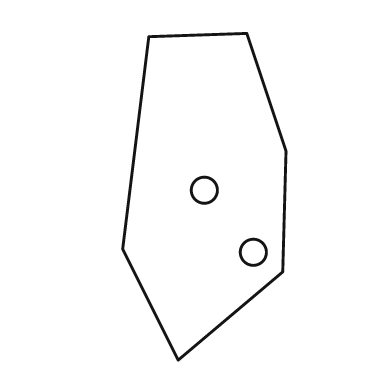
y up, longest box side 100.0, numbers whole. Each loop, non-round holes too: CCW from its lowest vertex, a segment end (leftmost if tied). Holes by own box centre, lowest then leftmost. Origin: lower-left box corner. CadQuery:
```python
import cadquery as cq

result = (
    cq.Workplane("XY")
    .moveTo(17.0, 0.0)
    .lineTo(49.0, 27.0)
    .lineTo(50.0, 64.0)
    .lineTo(38.0, 100.0)
    .lineTo(8.0, 99.0)
    .lineTo(0.0, 34.0)
    .close()
    .moveTo(40.0, 33.0)
    .circle(4.0)
    .moveTo(25.0, 52.0)
    .circle(4.0)
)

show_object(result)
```